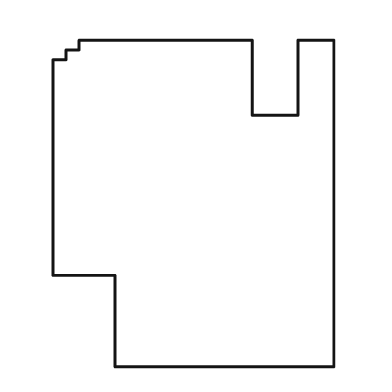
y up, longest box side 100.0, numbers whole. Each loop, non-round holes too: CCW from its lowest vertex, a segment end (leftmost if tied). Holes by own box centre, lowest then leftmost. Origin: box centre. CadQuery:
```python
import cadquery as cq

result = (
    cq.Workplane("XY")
    .moveTo(-24.0, -50.0)
    .lineTo(43.0, -50.0)
    .lineTo(43.0, 50.0)
    .lineTo(32.0, 50.0)
    .lineTo(32.0, 27.0)
    .lineTo(18.0, 27.0)
    .lineTo(18.0, 50.0)
    .lineTo(-35.0, 50.0)
    .lineTo(-35.0, 47.0)
    .lineTo(-39.0, 47.0)
    .lineTo(-39.0, 44.0)
    .lineTo(-43.0, 44.0)
    .lineTo(-43.0, -22.0)
    .lineTo(-24.0, -22.0)
    .close()
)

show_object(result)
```